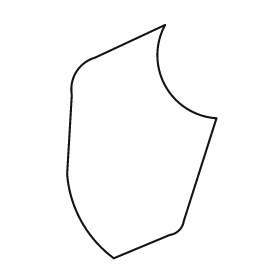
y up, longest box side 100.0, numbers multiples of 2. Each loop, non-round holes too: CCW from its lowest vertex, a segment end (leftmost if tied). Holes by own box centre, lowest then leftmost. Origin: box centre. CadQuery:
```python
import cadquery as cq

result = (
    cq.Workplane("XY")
    .moveTo(-12.0, -50.0)
    .lineTo(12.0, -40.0)
    .threePointArc((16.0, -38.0), (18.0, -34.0))
    .lineTo(32.0, 10.0)
    .threePointArc((10.0, 24.0), (10.0, 50.0))
    .lineTo(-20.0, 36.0)
    .threePointArc((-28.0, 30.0), (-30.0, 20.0))
    .lineTo(-32.0, -14.0)
    .threePointArc((-26.0, -34.0), (-12.0, -50.0))
    .close()
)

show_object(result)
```